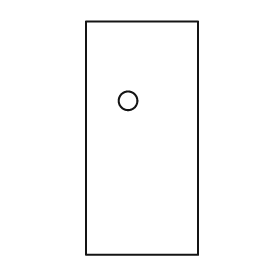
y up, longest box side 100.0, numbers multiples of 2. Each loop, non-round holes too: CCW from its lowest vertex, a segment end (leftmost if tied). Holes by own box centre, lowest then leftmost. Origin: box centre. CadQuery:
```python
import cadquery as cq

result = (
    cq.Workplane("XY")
    .moveTo(-24.0, -50.0)
    .lineTo(24.0, -50.0)
    .lineTo(24.0, 50.0)
    .lineTo(-24.0, 50.0)
    .close()
    .moveTo(-6.0, 16.0)
    .circle(4.0)
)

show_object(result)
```